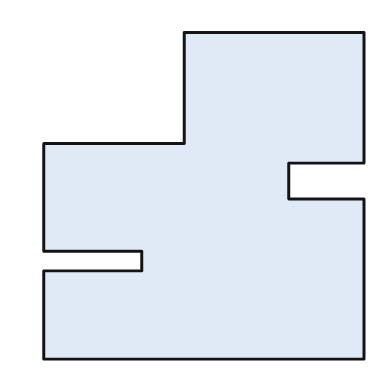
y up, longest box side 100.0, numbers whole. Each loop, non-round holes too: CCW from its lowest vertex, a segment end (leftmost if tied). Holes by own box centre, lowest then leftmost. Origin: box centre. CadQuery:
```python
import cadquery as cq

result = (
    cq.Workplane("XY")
    .moveTo(-49.0, -50.0)
    .lineTo(49.0, -50.0)
    .lineTo(49.0, -1.0)
    .lineTo(26.0, -1.0)
    .lineTo(26.0, 10.0)
    .lineTo(49.0, 10.0)
    .lineTo(49.0, 50.0)
    .lineTo(-6.0, 50.0)
    .lineTo(-6.0, 16.0)
    .lineTo(-49.0, 16.0)
    .lineTo(-49.0, -17.0)
    .lineTo(-19.0, -17.0)
    .lineTo(-19.0, -23.0)
    .lineTo(-49.0, -23.0)
    .close()
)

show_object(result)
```